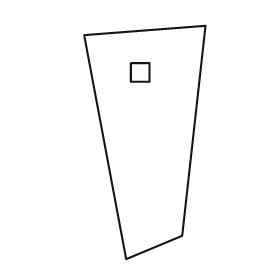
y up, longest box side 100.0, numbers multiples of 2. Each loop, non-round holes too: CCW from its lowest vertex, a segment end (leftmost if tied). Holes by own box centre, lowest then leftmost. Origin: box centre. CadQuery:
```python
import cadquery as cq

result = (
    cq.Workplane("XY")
    .moveTo(-8.0, -50.0)
    .lineTo(16.0, -40.0)
    .lineTo(26.0, 50.0)
    .lineTo(-26.0, 46.0)
    .close()
    .moveTo(-6.0, 26.0)
    .lineTo(2.0, 26.0)
    .lineTo(2.0, 34.0)
    .lineTo(-6.0, 34.0)
    .close()
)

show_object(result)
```